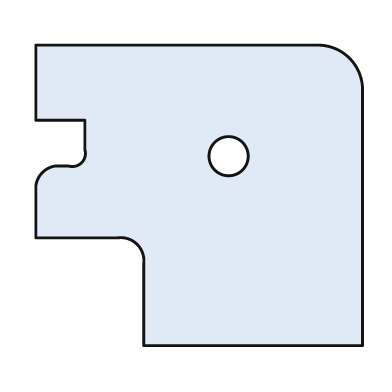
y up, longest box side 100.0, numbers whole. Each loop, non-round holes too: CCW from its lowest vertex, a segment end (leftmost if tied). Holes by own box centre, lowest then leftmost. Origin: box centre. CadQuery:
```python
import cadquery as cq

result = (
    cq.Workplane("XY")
    .moveTo(-17.0, -46.0)
    .lineTo(50.0, -46.0)
    .lineTo(50.0, 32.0)
    .threePointArc((46.0, 42.0), (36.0, 46.0))
    .lineTo(-50.0, 46.0)
    .lineTo(-50.0, 23.0)
    .lineTo(-35.0, 23.0)
    .lineTo(-35.0, 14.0)
    .threePointArc((-36.0, 10.0), (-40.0, 9.0))
    .lineTo(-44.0, 9.0)
    .threePointArc((-48.0, 7.0), (-50.0, 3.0))
    .lineTo(-50.0, -13.0)
    .lineTo(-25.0, -13.0)
    .threePointArc((-19.0, -15.0), (-17.0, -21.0))
    .close()
    .moveTo(9.0, 12.0)
    .circle(6.0)
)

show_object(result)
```